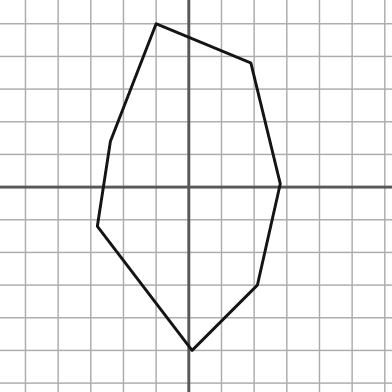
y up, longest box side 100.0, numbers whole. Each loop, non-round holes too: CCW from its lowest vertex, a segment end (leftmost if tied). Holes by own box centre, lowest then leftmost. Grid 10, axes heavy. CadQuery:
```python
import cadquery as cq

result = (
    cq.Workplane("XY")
    .moveTo(1.0, -50.0)
    .lineTo(21.0, -30.0)
    .lineTo(28.0, 1.0)
    .lineTo(19.0, 38.0)
    .lineTo(-10.0, 50.0)
    .lineTo(-24.0, 14.0)
    .lineTo(-28.0, -12.0)
    .close()
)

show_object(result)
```